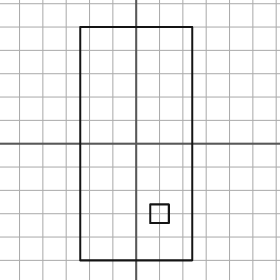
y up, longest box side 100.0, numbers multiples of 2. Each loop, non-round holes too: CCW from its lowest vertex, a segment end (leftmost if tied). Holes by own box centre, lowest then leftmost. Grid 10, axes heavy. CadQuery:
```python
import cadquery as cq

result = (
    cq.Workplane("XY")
    .moveTo(-24.0, -50.0)
    .lineTo(24.0, -50.0)
    .lineTo(24.0, 50.0)
    .lineTo(-24.0, 50.0)
    .close()
    .moveTo(6.0, -34.0)
    .lineTo(14.0, -34.0)
    .lineTo(14.0, -26.0)
    .lineTo(6.0, -26.0)
    .close()
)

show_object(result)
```